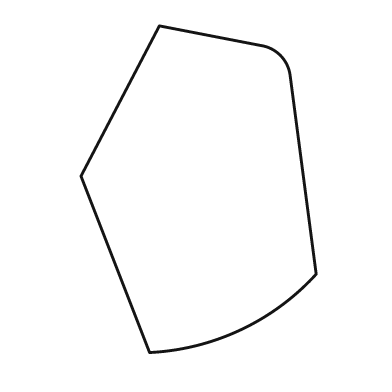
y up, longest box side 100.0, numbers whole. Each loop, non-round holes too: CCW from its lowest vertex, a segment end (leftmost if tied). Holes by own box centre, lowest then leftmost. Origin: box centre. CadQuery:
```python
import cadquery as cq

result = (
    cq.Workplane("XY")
    .moveTo(-15.0, -50.0)
    .threePointArc((13.0, -43.0), (36.0, -26.0))
    .lineTo(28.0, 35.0)
    .threePointArc((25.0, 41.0), (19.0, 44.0))
    .lineTo(-12.0, 50.0)
    .lineTo(-36.0, 4.0)
    .close()
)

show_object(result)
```